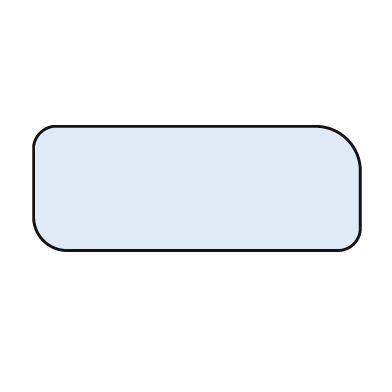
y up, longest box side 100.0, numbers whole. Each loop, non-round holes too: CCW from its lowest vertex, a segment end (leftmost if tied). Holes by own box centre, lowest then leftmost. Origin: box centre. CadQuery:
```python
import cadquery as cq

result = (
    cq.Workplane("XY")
    .moveTo(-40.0, -19.0)
    .lineTo(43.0, -19.0)
    .threePointArc((48.0, -17.0), (50.0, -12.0))
    .lineTo(50.0, 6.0)
    .threePointArc((46.0, 15.0), (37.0, 19.0))
    .lineTo(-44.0, 19.0)
    .threePointArc((-48.0, 17.0), (-50.0, 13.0))
    .lineTo(-50.0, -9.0)
    .threePointArc((-47.0, -16.0), (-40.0, -19.0))
    .close()
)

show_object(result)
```